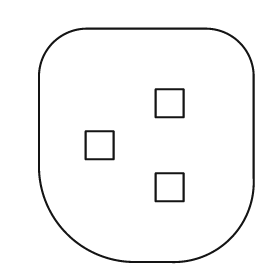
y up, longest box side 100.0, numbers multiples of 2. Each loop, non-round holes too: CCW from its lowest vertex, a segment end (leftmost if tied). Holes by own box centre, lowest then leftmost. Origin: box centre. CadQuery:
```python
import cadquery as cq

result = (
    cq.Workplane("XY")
    .moveTo(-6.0, -50.0)
    .lineTo(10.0, -50.0)
    .threePointArc((36.0, -40.0), (46.0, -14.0))
    .lineTo(46.0, 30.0)
    .threePointArc((40.0, 44.0), (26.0, 50.0))
    .lineTo(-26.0, 50.0)
    .threePointArc((-40.0, 44.0), (-46.0, 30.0))
    .lineTo(-46.0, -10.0)
    .threePointArc((-34.0, -38.0), (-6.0, -50.0))
    .close()
    .moveTo(4.0, -24.0)
    .lineTo(16.0, -24.0)
    .lineTo(16.0, -12.0)
    .lineTo(4.0, -12.0)
    .close()
    .moveTo(-26.0, -6.0)
    .lineTo(-14.0, -6.0)
    .lineTo(-14.0, 6.0)
    .lineTo(-26.0, 6.0)
    .close()
    .moveTo(4.0, 12.0)
    .lineTo(16.0, 12.0)
    .lineTo(16.0, 24.0)
    .lineTo(4.0, 24.0)
    .close()
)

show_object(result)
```